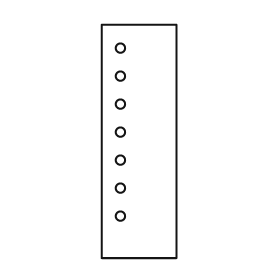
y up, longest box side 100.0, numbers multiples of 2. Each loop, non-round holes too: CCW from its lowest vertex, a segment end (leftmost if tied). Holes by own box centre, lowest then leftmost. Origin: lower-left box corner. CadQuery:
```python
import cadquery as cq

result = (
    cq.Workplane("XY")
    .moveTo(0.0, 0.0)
    .lineTo(32.0, 0.0)
    .lineTo(32.0, 100.0)
    .lineTo(0.0, 100.0)
    .close()
    .moveTo(8.0, 18.0)
    .circle(2.0)
    .moveTo(8.0, 30.0)
    .circle(2.0)
    .moveTo(8.0, 42.0)
    .circle(2.0)
    .moveTo(8.0, 54.0)
    .circle(2.0)
    .moveTo(8.0, 66.0)
    .circle(2.0)
    .moveTo(8.0, 78.0)
    .circle(2.0)
    .moveTo(8.0, 90.0)
    .circle(2.0)
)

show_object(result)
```